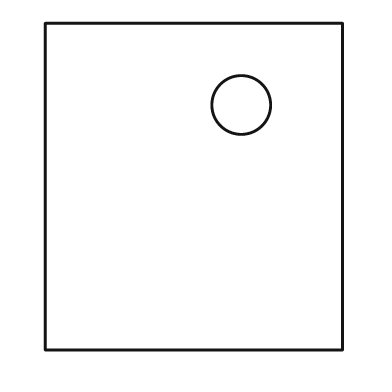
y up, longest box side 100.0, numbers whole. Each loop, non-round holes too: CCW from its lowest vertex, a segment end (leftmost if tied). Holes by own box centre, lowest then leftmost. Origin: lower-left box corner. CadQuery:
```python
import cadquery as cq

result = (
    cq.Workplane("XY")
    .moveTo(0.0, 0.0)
    .lineTo(91.0, 0.0)
    .lineTo(91.0, 100.0)
    .lineTo(0.0, 100.0)
    .close()
    .moveTo(60.0, 75.0)
    .circle(9.0)
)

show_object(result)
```